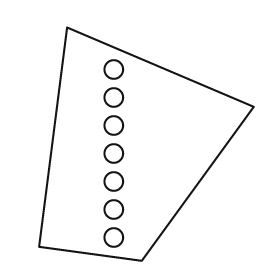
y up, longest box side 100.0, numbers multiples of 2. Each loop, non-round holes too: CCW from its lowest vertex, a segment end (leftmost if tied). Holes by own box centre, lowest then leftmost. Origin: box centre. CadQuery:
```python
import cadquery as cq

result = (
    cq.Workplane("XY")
    .moveTo(-2.0, -50.0)
    .lineTo(46.0, 16.0)
    .lineTo(-34.0, 50.0)
    .lineTo(-46.0, -44.0)
    .close()
    .moveTo(-14.0, -40.0)
    .circle(4.0)
    .moveTo(-14.0, -28.0)
    .circle(4.0)
    .moveTo(-14.0, -16.0)
    .circle(4.0)
    .moveTo(-14.0, -4.0)
    .circle(4.0)
    .moveTo(-14.0, 8.0)
    .circle(4.0)
    .moveTo(-14.0, 20.0)
    .circle(4.0)
    .moveTo(-14.0, 32.0)
    .circle(4.0)
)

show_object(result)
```